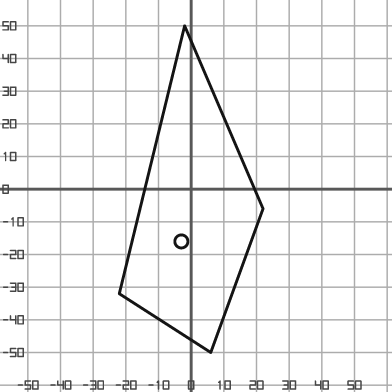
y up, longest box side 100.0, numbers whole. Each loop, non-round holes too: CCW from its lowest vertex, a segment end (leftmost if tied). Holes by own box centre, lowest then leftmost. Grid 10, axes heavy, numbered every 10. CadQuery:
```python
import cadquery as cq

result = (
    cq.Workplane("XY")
    .moveTo(6.0, -50.0)
    .lineTo(22.0, -6.0)
    .lineTo(-2.0, 50.0)
    .lineTo(-22.0, -32.0)
    .close()
    .moveTo(-3.0, -16.0)
    .circle(2.0)
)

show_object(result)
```